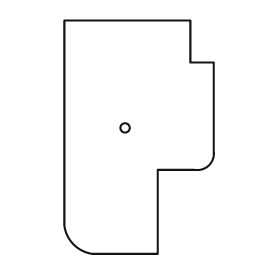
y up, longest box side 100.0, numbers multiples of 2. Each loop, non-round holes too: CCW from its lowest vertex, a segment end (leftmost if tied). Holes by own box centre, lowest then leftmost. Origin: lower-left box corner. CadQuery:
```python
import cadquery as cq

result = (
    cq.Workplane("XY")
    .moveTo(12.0, 0.0)
    .lineTo(40.0, 0.0)
    .lineTo(40.0, 36.0)
    .lineTo(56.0, 36.0)
    .threePointArc((62.0, 38.0), (64.0, 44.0))
    .lineTo(64.0, 82.0)
    .lineTo(54.0, 82.0)
    .lineTo(54.0, 100.0)
    .lineTo(0.0, 100.0)
    .lineTo(0.0, 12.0)
    .threePointArc((4.0, 4.0), (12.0, 0.0))
    .close()
    .moveTo(26.0, 54.0)
    .circle(2.0)
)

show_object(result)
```